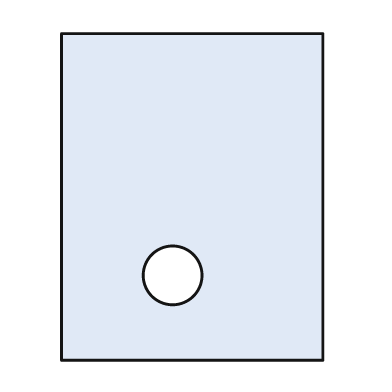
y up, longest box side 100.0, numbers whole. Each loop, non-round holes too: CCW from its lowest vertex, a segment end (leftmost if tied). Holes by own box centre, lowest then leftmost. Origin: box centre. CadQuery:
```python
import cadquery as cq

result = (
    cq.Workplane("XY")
    .moveTo(-40.0, -50.0)
    .lineTo(40.0, -50.0)
    .lineTo(40.0, 50.0)
    .lineTo(-40.0, 50.0)
    .close()
    .moveTo(-6.0, -24.0)
    .circle(9.0)
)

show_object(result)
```